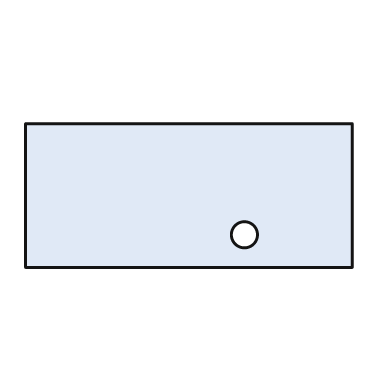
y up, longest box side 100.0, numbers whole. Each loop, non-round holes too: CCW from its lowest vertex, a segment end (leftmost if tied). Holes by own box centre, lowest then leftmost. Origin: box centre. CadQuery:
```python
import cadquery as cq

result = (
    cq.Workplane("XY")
    .moveTo(-50.0, -22.0)
    .lineTo(50.0, -22.0)
    .lineTo(50.0, 22.0)
    .lineTo(-50.0, 22.0)
    .close()
    .moveTo(17.0, -12.0)
    .circle(4.0)
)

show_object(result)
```